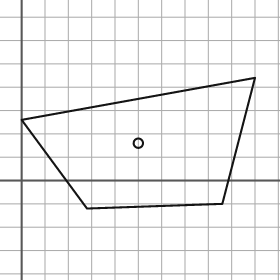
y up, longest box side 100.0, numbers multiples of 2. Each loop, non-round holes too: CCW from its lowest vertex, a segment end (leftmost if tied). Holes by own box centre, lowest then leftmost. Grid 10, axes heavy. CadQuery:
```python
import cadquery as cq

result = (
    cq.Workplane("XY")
    .moveTo(28.0, -12.0)
    .lineTo(86.0, -10.0)
    .lineTo(100.0, 44.0)
    .lineTo(0.0, 26.0)
    .close()
    .moveTo(50.0, 16.0)
    .circle(2.0)
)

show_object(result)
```